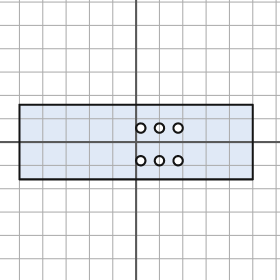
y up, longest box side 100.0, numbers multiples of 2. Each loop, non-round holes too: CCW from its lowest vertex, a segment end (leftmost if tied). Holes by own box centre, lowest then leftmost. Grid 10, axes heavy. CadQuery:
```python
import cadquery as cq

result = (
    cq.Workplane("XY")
    .moveTo(-50.0, -16.0)
    .lineTo(50.0, -16.0)
    .lineTo(50.0, 16.0)
    .lineTo(-50.0, 16.0)
    .close()
    .moveTo(2.0, -8.0)
    .circle(2.0)
    .moveTo(10.0, -8.0)
    .circle(2.0)
    .moveTo(18.0, -8.0)
    .circle(2.0)
    .moveTo(2.0, 6.0)
    .circle(2.0)
    .moveTo(10.0, 6.0)
    .circle(2.0)
    .moveTo(18.0, 6.0)
    .circle(2.0)
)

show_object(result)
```